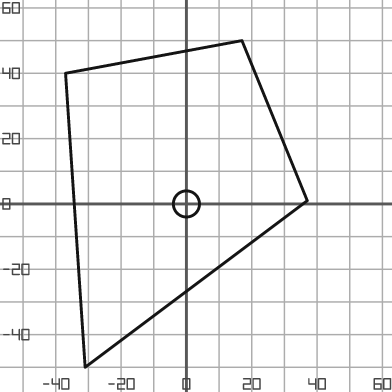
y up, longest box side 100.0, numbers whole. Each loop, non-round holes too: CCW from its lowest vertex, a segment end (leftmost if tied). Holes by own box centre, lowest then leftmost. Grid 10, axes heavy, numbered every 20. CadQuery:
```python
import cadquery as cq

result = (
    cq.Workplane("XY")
    .moveTo(-31.0, -50.0)
    .lineTo(37.0, 1.0)
    .lineTo(17.0, 50.0)
    .lineTo(-37.0, 40.0)
    .close()
    .moveTo(0.0, 0.0)
    .circle(4.0)
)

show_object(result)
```